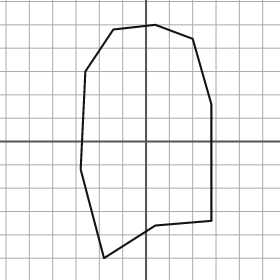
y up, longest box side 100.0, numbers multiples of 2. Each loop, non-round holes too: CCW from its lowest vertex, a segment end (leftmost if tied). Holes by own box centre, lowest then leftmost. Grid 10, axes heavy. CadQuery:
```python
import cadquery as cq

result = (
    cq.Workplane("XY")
    .moveTo(-18.0, -50.0)
    .lineTo(4.0, -36.0)
    .lineTo(28.0, -34.0)
    .lineTo(28.0, 16.0)
    .lineTo(20.0, 44.0)
    .lineTo(4.0, 50.0)
    .lineTo(-14.0, 48.0)
    .lineTo(-26.0, 30.0)
    .lineTo(-28.0, -12.0)
    .close()
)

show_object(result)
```